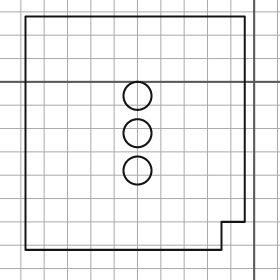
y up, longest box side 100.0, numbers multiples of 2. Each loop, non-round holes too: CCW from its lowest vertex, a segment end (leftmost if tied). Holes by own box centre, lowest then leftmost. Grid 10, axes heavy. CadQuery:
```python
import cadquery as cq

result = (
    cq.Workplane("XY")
    .moveTo(-98.0, -72.0)
    .lineTo(-14.0, -72.0)
    .lineTo(-14.0, -60.0)
    .lineTo(-4.0, -60.0)
    .lineTo(-4.0, 28.0)
    .lineTo(-98.0, 28.0)
    .close()
    .moveTo(-50.0, -38.0)
    .circle(6.0)
    .moveTo(-50.0, -22.0)
    .circle(6.0)
    .moveTo(-50.0, -6.0)
    .circle(6.0)
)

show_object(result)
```